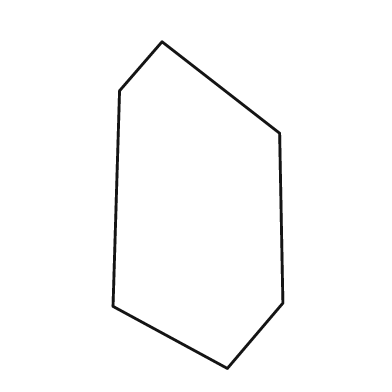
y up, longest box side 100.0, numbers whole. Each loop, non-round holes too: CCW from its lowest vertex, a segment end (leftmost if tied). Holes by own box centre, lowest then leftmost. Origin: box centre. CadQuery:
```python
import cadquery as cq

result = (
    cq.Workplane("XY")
    .moveTo(9.0, -50.0)
    .lineTo(26.0, -30.0)
    .lineTo(25.0, 22.0)
    .lineTo(-11.0, 50.0)
    .lineTo(-24.0, 35.0)
    .lineTo(-26.0, -31.0)
    .close()
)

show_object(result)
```